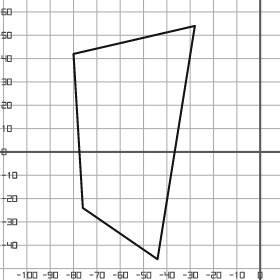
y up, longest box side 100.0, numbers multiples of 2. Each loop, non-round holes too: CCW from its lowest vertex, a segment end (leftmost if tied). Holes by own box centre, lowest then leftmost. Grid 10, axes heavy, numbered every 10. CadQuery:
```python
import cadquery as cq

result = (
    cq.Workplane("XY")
    .moveTo(-44.0, -46.0)
    .lineTo(-28.0, 54.0)
    .lineTo(-80.0, 42.0)
    .lineTo(-76.0, -24.0)
    .close()
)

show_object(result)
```